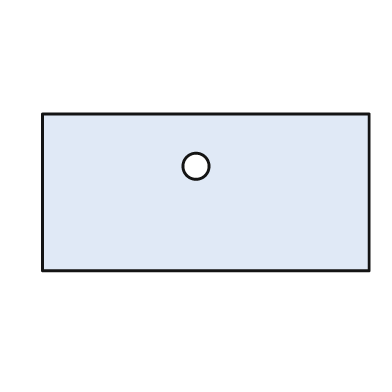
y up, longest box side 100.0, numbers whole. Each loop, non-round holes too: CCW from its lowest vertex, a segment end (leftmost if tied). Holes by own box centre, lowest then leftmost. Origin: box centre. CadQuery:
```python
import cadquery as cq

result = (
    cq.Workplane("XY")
    .moveTo(-50.0, -24.0)
    .lineTo(50.0, -24.0)
    .lineTo(50.0, 24.0)
    .lineTo(-50.0, 24.0)
    .close()
    .moveTo(-3.0, 8.0)
    .circle(4.0)
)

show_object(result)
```